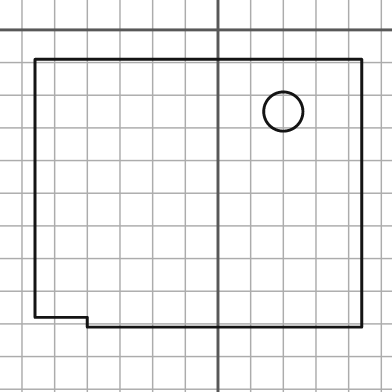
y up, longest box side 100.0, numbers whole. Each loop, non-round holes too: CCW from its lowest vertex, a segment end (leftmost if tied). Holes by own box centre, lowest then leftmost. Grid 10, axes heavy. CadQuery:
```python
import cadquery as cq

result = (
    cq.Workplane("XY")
    .moveTo(-40.0, -91.0)
    .lineTo(44.0, -91.0)
    .lineTo(44.0, -9.0)
    .lineTo(-56.0, -9.0)
    .lineTo(-56.0, -88.0)
    .lineTo(-40.0, -88.0)
    .close()
    .moveTo(20.0, -25.0)
    .circle(6.0)
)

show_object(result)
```